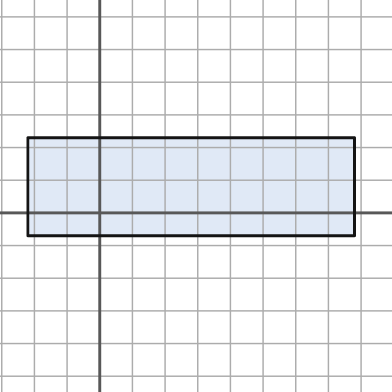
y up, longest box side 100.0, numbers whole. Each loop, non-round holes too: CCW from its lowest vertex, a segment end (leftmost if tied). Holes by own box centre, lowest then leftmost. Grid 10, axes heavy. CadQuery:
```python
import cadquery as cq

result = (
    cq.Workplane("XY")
    .moveTo(-22.0, -7.0)
    .lineTo(78.0, -7.0)
    .lineTo(78.0, 23.0)
    .lineTo(-22.0, 23.0)
    .close()
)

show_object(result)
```